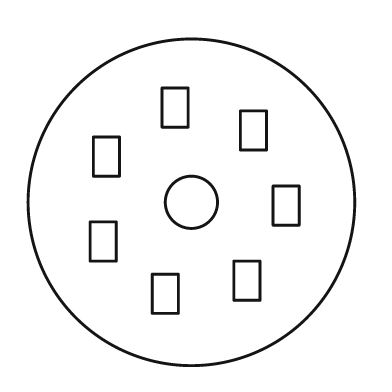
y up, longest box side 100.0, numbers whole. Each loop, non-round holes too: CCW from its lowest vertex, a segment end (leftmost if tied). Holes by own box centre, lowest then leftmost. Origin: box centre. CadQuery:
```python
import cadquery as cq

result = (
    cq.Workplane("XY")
    .moveTo(0.0, 0.0)
    .circle(50.0)
    .moveTo(-12.0, -34.0)
    .lineTo(-4.0, -34.0)
    .lineTo(-4.0, -22.0)
    .lineTo(-12.0, -22.0)
    .close()
    .moveTo(13.0, -30.0)
    .lineTo(21.0, -30.0)
    .lineTo(21.0, -18.0)
    .lineTo(13.0, -18.0)
    .close()
    .moveTo(-31.0, -18.0)
    .lineTo(-23.0, -18.0)
    .lineTo(-23.0, -6.0)
    .lineTo(-31.0, -6.0)
    .close()
    .moveTo(25.0, -7.0)
    .lineTo(33.0, -7.0)
    .lineTo(33.0, 5.0)
    .lineTo(25.0, 5.0)
    .close()
    .moveTo(0.0, 0.0)
    .circle(8.0)
    .moveTo(-30.0, 8.0)
    .lineTo(-22.0, 8.0)
    .lineTo(-22.0, 20.0)
    .lineTo(-30.0, 20.0)
    .close()
    .moveTo(15.0, 16.0)
    .lineTo(23.0, 16.0)
    .lineTo(23.0, 28.0)
    .lineTo(15.0, 28.0)
    .close()
    .moveTo(-9.0, 23.0)
    .lineTo(-1.0, 23.0)
    .lineTo(-1.0, 35.0)
    .lineTo(-9.0, 35.0)
    .close()
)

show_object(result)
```